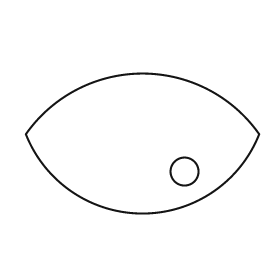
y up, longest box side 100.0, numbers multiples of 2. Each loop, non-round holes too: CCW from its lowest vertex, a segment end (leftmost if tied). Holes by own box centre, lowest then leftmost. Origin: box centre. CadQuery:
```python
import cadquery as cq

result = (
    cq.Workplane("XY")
    .moveTo(-50.0, 4.0)
    .threePointArc((0.0, -30.0), (50.0, 4.0))
    .threePointArc((0.0, 30.0), (-50.0, 4.0))
    .close()
    .moveTo(18.0, -12.0)
    .circle(6.0)
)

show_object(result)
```